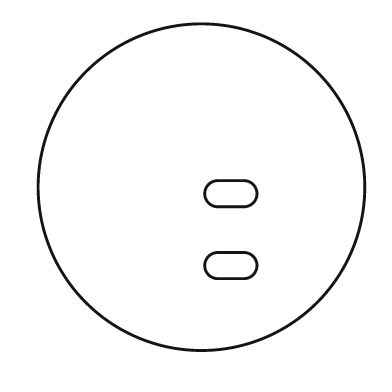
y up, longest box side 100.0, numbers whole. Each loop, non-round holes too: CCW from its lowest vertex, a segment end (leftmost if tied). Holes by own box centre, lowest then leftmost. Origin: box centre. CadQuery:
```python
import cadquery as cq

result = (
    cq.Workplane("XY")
    .moveTo(0.0, 0.0)
    .circle(50.0)
    .moveTo(5.0, -28.0)
    .lineTo(13.0, -28.0)
    .threePointArc((17.0, -24.0), (13.0, -20.0))
    .lineTo(5.0, -20.0)
    .threePointArc((1.0, -24.0), (5.0, -28.0))
    .close()
    .moveTo(5.0, -6.0)
    .lineTo(13.0, -6.0)
    .threePointArc((17.0, -2.0), (13.0, 2.0))
    .lineTo(5.0, 2.0)
    .threePointArc((1.0, -2.0), (5.0, -6.0))
    .close()
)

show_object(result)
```